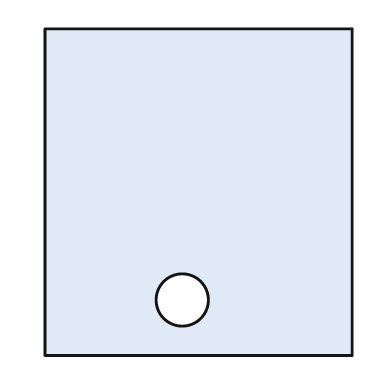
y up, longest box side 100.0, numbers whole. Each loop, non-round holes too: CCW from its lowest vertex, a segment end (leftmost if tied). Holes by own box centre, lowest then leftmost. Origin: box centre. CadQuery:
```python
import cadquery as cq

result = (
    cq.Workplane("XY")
    .moveTo(-47.0, -50.0)
    .lineTo(47.0, -50.0)
    .lineTo(47.0, 50.0)
    .lineTo(-47.0, 50.0)
    .close()
    .moveTo(-5.0, -33.0)
    .circle(8.0)
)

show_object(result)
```